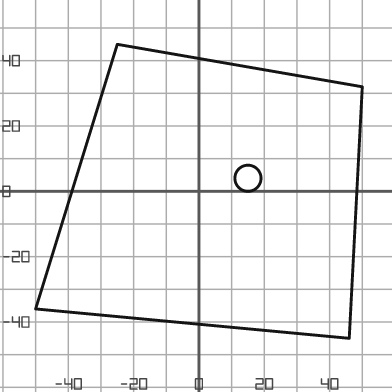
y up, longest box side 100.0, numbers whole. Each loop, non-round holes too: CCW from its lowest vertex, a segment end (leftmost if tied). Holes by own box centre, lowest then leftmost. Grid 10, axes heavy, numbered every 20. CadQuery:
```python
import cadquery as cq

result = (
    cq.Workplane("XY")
    .moveTo(46.0, -45.0)
    .lineTo(50.0, 32.0)
    .lineTo(-25.0, 45.0)
    .lineTo(-50.0, -36.0)
    .close()
    .moveTo(15.0, 4.0)
    .circle(4.0)
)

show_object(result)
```